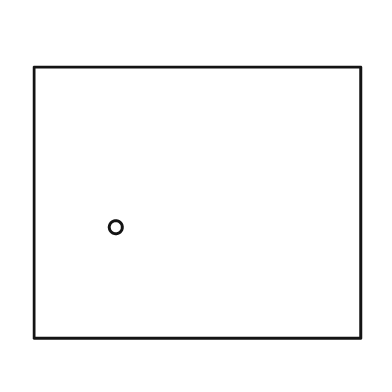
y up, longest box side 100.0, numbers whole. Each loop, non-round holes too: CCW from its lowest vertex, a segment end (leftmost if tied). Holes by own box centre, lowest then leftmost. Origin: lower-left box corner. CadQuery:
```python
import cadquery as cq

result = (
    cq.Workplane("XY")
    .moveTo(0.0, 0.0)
    .lineTo(100.0, 0.0)
    .lineTo(100.0, 83.0)
    .lineTo(0.0, 83.0)
    .close()
    .moveTo(25.0, 34.0)
    .circle(2.0)
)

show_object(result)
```